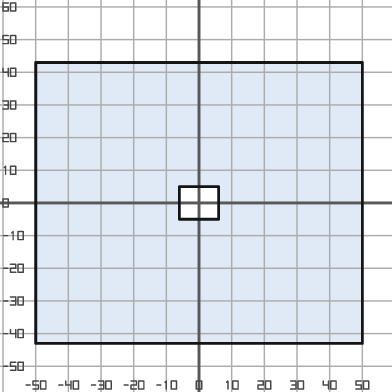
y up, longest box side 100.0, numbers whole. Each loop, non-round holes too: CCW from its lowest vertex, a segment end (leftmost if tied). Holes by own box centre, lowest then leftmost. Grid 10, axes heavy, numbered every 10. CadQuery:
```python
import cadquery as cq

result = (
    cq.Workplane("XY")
    .moveTo(-50.0, -43.0)
    .lineTo(50.0, -43.0)
    .lineTo(50.0, 43.0)
    .lineTo(-50.0, 43.0)
    .close()
    .moveTo(-6.0, -5.0)
    .lineTo(6.0, -5.0)
    .lineTo(6.0, 5.0)
    .lineTo(-6.0, 5.0)
    .close()
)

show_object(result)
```